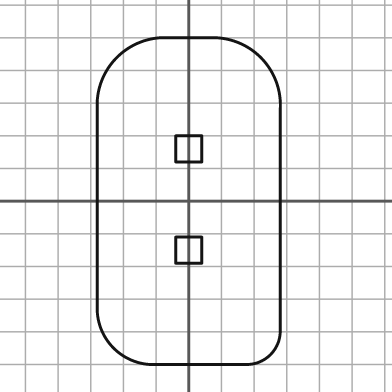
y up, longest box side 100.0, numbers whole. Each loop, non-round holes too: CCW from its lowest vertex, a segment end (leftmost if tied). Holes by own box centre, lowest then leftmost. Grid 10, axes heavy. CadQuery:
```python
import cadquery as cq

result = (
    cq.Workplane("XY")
    .moveTo(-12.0, -50.0)
    .lineTo(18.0, -50.0)
    .threePointArc((25.0, -47.0), (28.0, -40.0))
    .lineTo(28.0, 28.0)
    .threePointArc((22.0, 44.0), (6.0, 50.0))
    .lineTo(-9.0, 50.0)
    .threePointArc((-22.0, 44.0), (-28.0, 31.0))
    .lineTo(-28.0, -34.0)
    .threePointArc((-23.0, -45.0), (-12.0, -50.0))
    .close()
    .moveTo(-4.0, -19.0)
    .lineTo(4.0, -19.0)
    .lineTo(4.0, -11.0)
    .lineTo(-4.0, -11.0)
    .close()
    .moveTo(-4.0, 12.0)
    .lineTo(4.0, 12.0)
    .lineTo(4.0, 20.0)
    .lineTo(-4.0, 20.0)
    .close()
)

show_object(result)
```